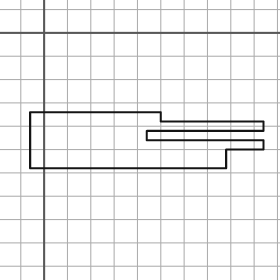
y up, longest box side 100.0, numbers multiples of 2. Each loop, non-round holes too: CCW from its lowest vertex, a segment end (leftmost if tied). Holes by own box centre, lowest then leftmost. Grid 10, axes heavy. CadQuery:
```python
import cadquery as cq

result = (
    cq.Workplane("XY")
    .moveTo(-6.0, -58.0)
    .lineTo(78.0, -58.0)
    .lineTo(78.0, -50.0)
    .lineTo(94.0, -50.0)
    .lineTo(94.0, -46.0)
    .lineTo(44.0, -46.0)
    .lineTo(44.0, -42.0)
    .lineTo(94.0, -42.0)
    .lineTo(94.0, -38.0)
    .lineTo(50.0, -38.0)
    .lineTo(50.0, -34.0)
    .lineTo(-6.0, -34.0)
    .close()
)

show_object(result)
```